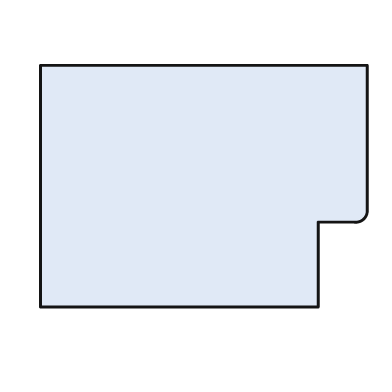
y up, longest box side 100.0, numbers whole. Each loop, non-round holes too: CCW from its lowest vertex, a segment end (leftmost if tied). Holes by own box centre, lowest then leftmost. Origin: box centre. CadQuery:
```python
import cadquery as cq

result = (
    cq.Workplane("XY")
    .moveTo(-50.0, -37.0)
    .lineTo(35.0, -37.0)
    .lineTo(35.0, -11.0)
    .lineTo(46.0, -11.0)
    .threePointArc((49.0, -10.0), (50.0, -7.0))
    .lineTo(50.0, 37.0)
    .lineTo(-50.0, 37.0)
    .close()
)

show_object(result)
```